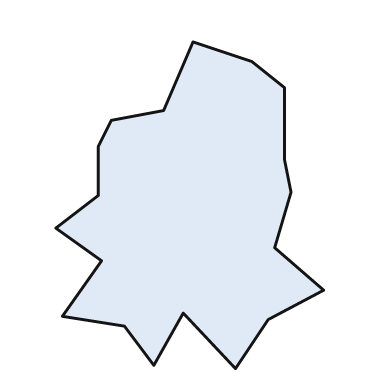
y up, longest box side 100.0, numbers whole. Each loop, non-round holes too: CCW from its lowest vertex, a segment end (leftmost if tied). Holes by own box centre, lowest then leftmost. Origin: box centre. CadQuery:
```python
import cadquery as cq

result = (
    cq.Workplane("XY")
    .moveTo(14.0, -50.0)
    .lineTo(24.0, -35.0)
    .lineTo(41.0, -26.0)
    .lineTo(26.0, -13.0)
    .lineTo(31.0, 4.0)
    .lineTo(29.0, 14.0)
    .lineTo(29.0, 36.0)
    .lineTo(19.0, 44.0)
    .lineTo(1.0, 50.0)
    .lineTo(-8.0, 29.0)
    .lineTo(-24.0, 26.0)
    .lineTo(-28.0, 18.0)
    .lineTo(-28.0, 3.0)
    .lineTo(-41.0, -7.0)
    .lineTo(-27.0, -17.0)
    .lineTo(-39.0, -34.0)
    .lineTo(-20.0, -37.0)
    .lineTo(-11.0, -49.0)
    .lineTo(-2.0, -33.0)
    .close()
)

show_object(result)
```